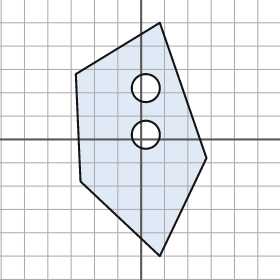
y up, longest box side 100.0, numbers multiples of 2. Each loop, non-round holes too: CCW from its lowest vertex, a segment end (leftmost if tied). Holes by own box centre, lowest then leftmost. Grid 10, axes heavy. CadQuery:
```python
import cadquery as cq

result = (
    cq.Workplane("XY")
    .moveTo(8.0, -50.0)
    .lineTo(28.0, -8.0)
    .lineTo(8.0, 50.0)
    .lineTo(-28.0, 28.0)
    .lineTo(-26.0, -18.0)
    .close()
    .moveTo(2.0, 2.0)
    .circle(6.0)
    .moveTo(2.0, 22.0)
    .circle(6.0)
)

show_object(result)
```